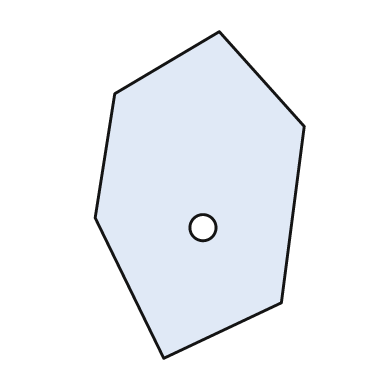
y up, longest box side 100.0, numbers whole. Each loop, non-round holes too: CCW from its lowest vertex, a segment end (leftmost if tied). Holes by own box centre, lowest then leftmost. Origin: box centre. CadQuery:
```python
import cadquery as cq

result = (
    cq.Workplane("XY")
    .moveTo(-11.0, -50.0)
    .lineTo(25.0, -33.0)
    .lineTo(32.0, 21.0)
    .lineTo(6.0, 50.0)
    .lineTo(-26.0, 31.0)
    .lineTo(-32.0, -7.0)
    .close()
    .moveTo(1.0, -10.0)
    .circle(4.0)
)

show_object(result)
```